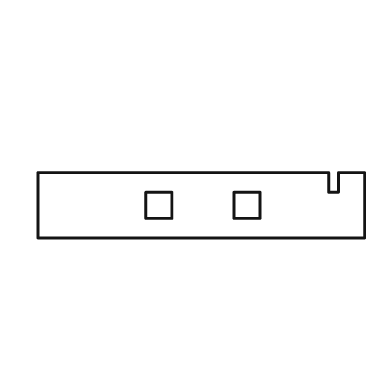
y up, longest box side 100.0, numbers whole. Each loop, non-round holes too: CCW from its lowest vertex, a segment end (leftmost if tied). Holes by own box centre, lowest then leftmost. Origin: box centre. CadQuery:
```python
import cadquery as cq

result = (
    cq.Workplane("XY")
    .moveTo(-50.0, -10.0)
    .lineTo(50.0, -10.0)
    .lineTo(50.0, 10.0)
    .lineTo(42.0, 10.0)
    .lineTo(42.0, 4.0)
    .lineTo(39.0, 4.0)
    .lineTo(39.0, 10.0)
    .lineTo(-50.0, 10.0)
    .close()
    .moveTo(-17.0, -4.0)
    .lineTo(-9.0, -4.0)
    .lineTo(-9.0, 4.0)
    .lineTo(-17.0, 4.0)
    .close()
    .moveTo(10.0, -4.0)
    .lineTo(18.0, -4.0)
    .lineTo(18.0, 4.0)
    .lineTo(10.0, 4.0)
    .close()
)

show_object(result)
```